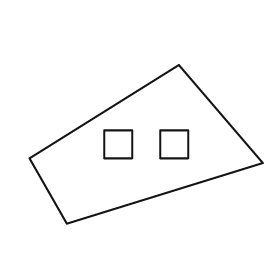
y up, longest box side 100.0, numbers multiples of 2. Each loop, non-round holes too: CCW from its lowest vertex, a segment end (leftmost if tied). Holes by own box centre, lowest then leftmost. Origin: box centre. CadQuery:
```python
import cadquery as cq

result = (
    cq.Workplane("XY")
    .moveTo(-34.0, -34.0)
    .lineTo(50.0, -8.0)
    .lineTo(14.0, 34.0)
    .lineTo(-50.0, -6.0)
    .close()
    .moveTo(-18.0, -6.0)
    .lineTo(-6.0, -6.0)
    .lineTo(-6.0, 6.0)
    .lineTo(-18.0, 6.0)
    .close()
    .moveTo(6.0, -6.0)
    .lineTo(18.0, -6.0)
    .lineTo(18.0, 6.0)
    .lineTo(6.0, 6.0)
    .close()
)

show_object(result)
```